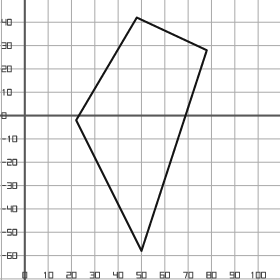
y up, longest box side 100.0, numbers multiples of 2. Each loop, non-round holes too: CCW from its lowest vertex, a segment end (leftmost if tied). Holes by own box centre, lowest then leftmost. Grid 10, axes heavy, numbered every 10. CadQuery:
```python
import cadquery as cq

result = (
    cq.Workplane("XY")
    .moveTo(50.0, -58.0)
    .lineTo(78.0, 28.0)
    .lineTo(48.0, 42.0)
    .lineTo(22.0, -2.0)
    .close()
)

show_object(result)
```